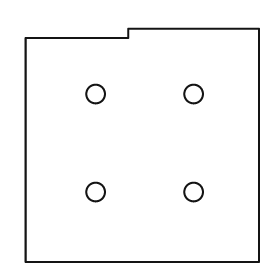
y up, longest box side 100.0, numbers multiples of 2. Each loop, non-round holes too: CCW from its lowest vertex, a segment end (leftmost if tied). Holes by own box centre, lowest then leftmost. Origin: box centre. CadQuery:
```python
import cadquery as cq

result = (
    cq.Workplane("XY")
    .moveTo(-50.0, -50.0)
    .lineTo(50.0, -50.0)
    .lineTo(50.0, 50.0)
    .lineTo(-6.0, 50.0)
    .lineTo(-6.0, 46.0)
    .lineTo(-50.0, 46.0)
    .close()
    .moveTo(-20.0, -20.0)
    .circle(4.0)
    .moveTo(22.0, -20.0)
    .circle(4.0)
    .moveTo(-20.0, 22.0)
    .circle(4.0)
    .moveTo(22.0, 22.0)
    .circle(4.0)
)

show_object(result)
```